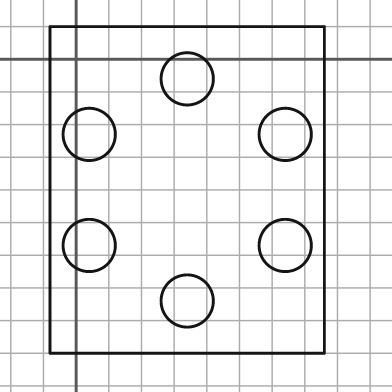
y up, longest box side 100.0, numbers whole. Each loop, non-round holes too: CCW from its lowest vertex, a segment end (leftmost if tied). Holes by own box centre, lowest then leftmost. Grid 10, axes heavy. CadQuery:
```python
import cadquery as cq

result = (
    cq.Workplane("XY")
    .moveTo(-8.0, -90.0)
    .lineTo(76.0, -90.0)
    .lineTo(76.0, 10.0)
    .lineTo(-8.0, 10.0)
    .close()
    .moveTo(34.0, -74.0)
    .circle(8.0)
    .moveTo(4.0, -57.0)
    .circle(8.0)
    .moveTo(64.0, -57.0)
    .circle(8.0)
    .moveTo(4.0, -23.0)
    .circle(8.0)
    .moveTo(64.0, -23.0)
    .circle(8.0)
    .moveTo(34.0, -6.0)
    .circle(8.0)
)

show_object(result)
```